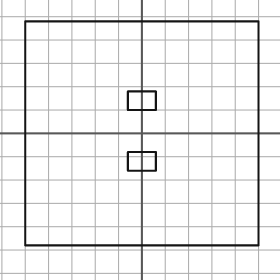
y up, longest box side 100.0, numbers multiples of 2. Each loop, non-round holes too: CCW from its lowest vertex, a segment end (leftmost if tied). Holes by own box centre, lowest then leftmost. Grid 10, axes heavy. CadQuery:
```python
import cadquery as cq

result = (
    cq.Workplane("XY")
    .moveTo(-50.0, -48.0)
    .lineTo(50.0, -48.0)
    .lineTo(50.0, 48.0)
    .lineTo(-50.0, 48.0)
    .close()
    .moveTo(-6.0, -16.0)
    .lineTo(6.0, -16.0)
    .lineTo(6.0, -8.0)
    .lineTo(-6.0, -8.0)
    .close()
    .moveTo(-6.0, 10.0)
    .lineTo(6.0, 10.0)
    .lineTo(6.0, 18.0)
    .lineTo(-6.0, 18.0)
    .close()
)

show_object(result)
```